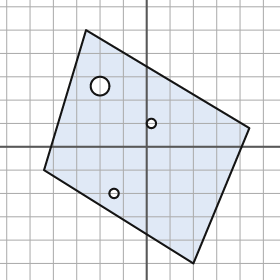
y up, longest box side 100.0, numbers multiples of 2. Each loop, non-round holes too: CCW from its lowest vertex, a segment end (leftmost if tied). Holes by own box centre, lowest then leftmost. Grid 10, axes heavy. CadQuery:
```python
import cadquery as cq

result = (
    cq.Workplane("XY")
    .moveTo(20.0, -50.0)
    .lineTo(44.0, 8.0)
    .lineTo(-26.0, 50.0)
    .lineTo(-44.0, -10.0)
    .close()
    .moveTo(-14.0, -20.0)
    .circle(2.0)
    .moveTo(2.0, 10.0)
    .circle(2.0)
    .moveTo(-20.0, 26.0)
    .circle(4.0)
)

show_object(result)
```